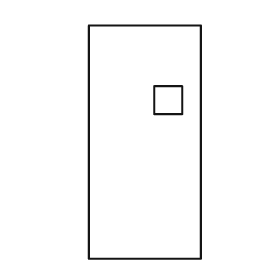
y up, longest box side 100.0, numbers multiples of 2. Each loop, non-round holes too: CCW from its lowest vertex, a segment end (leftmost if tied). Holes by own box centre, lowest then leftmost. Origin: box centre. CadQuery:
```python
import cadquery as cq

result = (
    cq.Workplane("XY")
    .moveTo(-24.0, -50.0)
    .lineTo(24.0, -50.0)
    .lineTo(24.0, 50.0)
    .lineTo(-24.0, 50.0)
    .close()
    .moveTo(4.0, 12.0)
    .lineTo(16.0, 12.0)
    .lineTo(16.0, 24.0)
    .lineTo(4.0, 24.0)
    .close()
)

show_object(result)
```